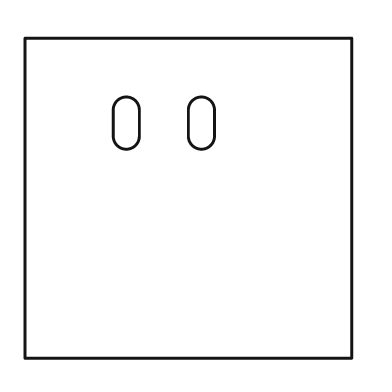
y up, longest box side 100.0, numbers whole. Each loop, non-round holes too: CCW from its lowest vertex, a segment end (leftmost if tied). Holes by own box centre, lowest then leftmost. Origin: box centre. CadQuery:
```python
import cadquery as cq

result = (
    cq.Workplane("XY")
    .moveTo(-50.0, -49.0)
    .lineTo(50.0, -49.0)
    .lineTo(50.0, 49.0)
    .lineTo(-50.0, 49.0)
    .close()
    .moveTo(-23.0, 19.0)
    .threePointArc((-19.0, 15.0), (-15.0, 19.0))
    .lineTo(-15.0, 27.0)
    .threePointArc((-19.0, 31.0), (-23.0, 27.0))
    .close()
    .moveTo(0.0, 19.0)
    .threePointArc((4.0, 15.0), (8.0, 19.0))
    .lineTo(8.0, 27.0)
    .threePointArc((4.0, 31.0), (0.0, 27.0))
    .close()
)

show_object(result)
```